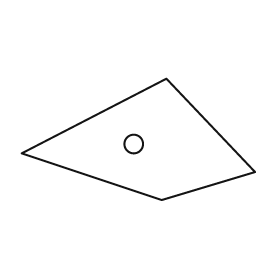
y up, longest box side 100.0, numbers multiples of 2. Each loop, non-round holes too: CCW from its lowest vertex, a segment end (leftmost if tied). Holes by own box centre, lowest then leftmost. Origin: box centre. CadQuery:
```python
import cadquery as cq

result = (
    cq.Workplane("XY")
    .moveTo(10.0, -26.0)
    .lineTo(50.0, -14.0)
    .lineTo(12.0, 26.0)
    .lineTo(-50.0, -6.0)
    .close()
    .moveTo(-2.0, -2.0)
    .circle(4.0)
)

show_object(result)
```